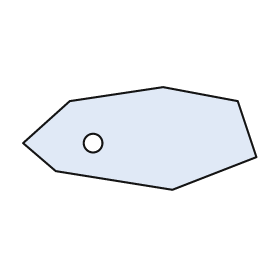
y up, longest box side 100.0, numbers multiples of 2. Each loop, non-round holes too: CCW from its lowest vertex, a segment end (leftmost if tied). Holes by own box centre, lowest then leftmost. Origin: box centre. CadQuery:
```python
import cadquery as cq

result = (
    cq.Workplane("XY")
    .moveTo(14.0, -22.0)
    .lineTo(50.0, -8.0)
    .lineTo(42.0, 16.0)
    .lineTo(10.0, 22.0)
    .lineTo(-30.0, 16.0)
    .lineTo(-50.0, -2.0)
    .lineTo(-36.0, -14.0)
    .close()
    .moveTo(-20.0, -2.0)
    .circle(4.0)
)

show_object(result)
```